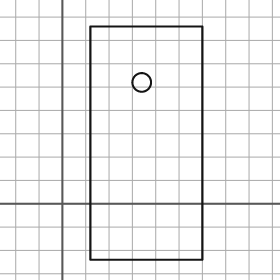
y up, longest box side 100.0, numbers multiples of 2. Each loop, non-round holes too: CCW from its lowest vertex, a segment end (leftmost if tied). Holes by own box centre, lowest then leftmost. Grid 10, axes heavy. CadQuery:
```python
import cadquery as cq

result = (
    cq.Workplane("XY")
    .moveTo(12.0, -24.0)
    .lineTo(60.0, -24.0)
    .lineTo(60.0, 76.0)
    .lineTo(12.0, 76.0)
    .close()
    .moveTo(34.0, 52.0)
    .circle(4.0)
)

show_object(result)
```